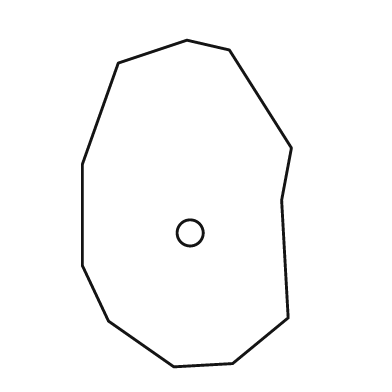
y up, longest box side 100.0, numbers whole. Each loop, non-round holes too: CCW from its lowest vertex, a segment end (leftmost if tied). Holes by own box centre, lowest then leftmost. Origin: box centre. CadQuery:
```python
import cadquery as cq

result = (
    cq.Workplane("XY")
    .moveTo(-4.0, -50.0)
    .lineTo(14.0, -49.0)
    .lineTo(31.0, -35.0)
    .lineTo(29.0, 1.0)
    .lineTo(32.0, 17.0)
    .lineTo(13.0, 47.0)
    .lineTo(0.0, 50.0)
    .lineTo(-21.0, 43.0)
    .lineTo(-32.0, 12.0)
    .lineTo(-32.0, -19.0)
    .lineTo(-24.0, -36.0)
    .close()
    .moveTo(1.0, -9.0)
    .circle(4.0)
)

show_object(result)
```